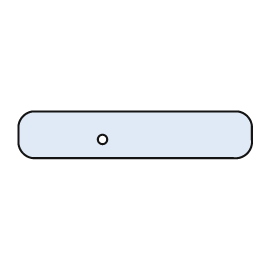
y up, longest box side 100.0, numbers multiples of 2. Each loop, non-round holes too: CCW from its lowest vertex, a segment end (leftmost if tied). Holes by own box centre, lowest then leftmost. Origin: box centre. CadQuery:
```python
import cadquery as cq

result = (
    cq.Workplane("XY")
    .moveTo(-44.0, -10.0)
    .lineTo(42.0, -10.0)
    .threePointArc((48.0, -8.0), (50.0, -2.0))
    .lineTo(50.0, 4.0)
    .threePointArc((48.0, 8.0), (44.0, 10.0))
    .lineTo(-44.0, 10.0)
    .threePointArc((-48.0, 8.0), (-50.0, 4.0))
    .lineTo(-50.0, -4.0)
    .threePointArc((-48.0, -8.0), (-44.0, -10.0))
    .close()
    .moveTo(-14.0, -2.0)
    .circle(2.0)
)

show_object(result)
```